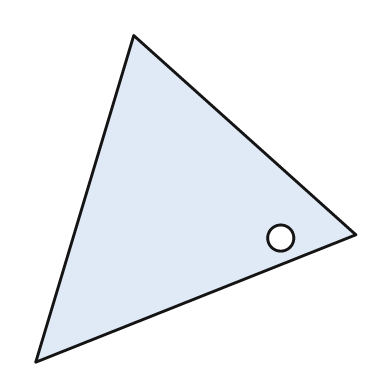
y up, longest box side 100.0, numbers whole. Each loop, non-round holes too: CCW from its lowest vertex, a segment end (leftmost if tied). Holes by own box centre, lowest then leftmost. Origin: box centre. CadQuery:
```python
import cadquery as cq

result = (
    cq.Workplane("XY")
    .moveTo(-49.0, -50.0)
    .lineTo(49.0, -11.0)
    .lineTo(-19.0, 50.0)
    .close()
    .moveTo(26.0, -12.0)
    .circle(4.0)
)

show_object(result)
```